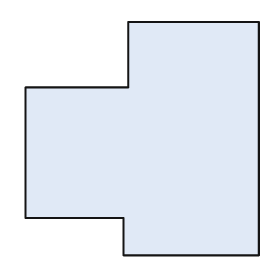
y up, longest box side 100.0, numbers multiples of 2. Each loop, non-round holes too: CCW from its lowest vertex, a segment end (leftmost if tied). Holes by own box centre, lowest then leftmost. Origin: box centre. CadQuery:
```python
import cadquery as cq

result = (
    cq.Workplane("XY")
    .moveTo(-8.0, -50.0)
    .lineTo(50.0, -50.0)
    .lineTo(50.0, 50.0)
    .lineTo(-6.0, 50.0)
    .lineTo(-6.0, 22.0)
    .lineTo(-50.0, 22.0)
    .lineTo(-50.0, -34.0)
    .lineTo(-8.0, -34.0)
    .close()
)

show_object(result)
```